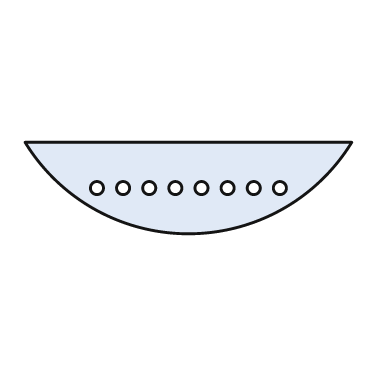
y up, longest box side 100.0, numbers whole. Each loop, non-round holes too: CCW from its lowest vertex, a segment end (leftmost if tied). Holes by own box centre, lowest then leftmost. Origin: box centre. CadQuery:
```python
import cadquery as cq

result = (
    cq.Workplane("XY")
    .moveTo(-50.0, 14.0)
    .threePointArc((0.0, -14.0), (50.0, 14.0))
    .close()
    .moveTo(-28.0, 0.0)
    .circle(2.0)
    .moveTo(-20.0, 0.0)
    .circle(2.0)
    .moveTo(-12.0, 0.0)
    .circle(2.0)
    .moveTo(-4.0, 0.0)
    .circle(2.0)
    .moveTo(4.0, 0.0)
    .circle(2.0)
    .moveTo(12.0, 0.0)
    .circle(2.0)
    .moveTo(20.0, 0.0)
    .circle(2.0)
    .moveTo(28.0, 0.0)
    .circle(2.0)
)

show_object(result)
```